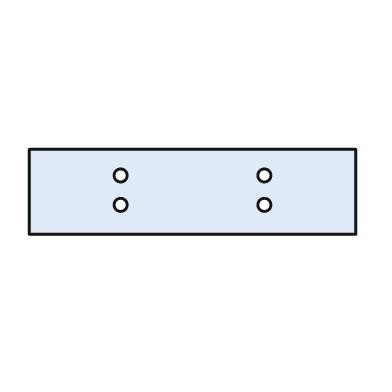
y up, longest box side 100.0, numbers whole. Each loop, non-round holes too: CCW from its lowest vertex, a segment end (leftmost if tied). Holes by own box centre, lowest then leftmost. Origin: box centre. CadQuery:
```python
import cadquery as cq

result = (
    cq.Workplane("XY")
    .moveTo(-50.0, -13.0)
    .lineTo(50.0, -13.0)
    .lineTo(50.0, 13.0)
    .lineTo(-50.0, 13.0)
    .close()
    .moveTo(-22.0, -4.0)
    .circle(2.0)
    .moveTo(22.0, -4.0)
    .circle(2.0)
    .moveTo(-22.0, 5.0)
    .circle(2.0)
    .moveTo(22.0, 5.0)
    .circle(2.0)
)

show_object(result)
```